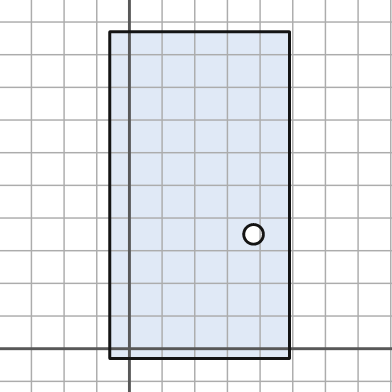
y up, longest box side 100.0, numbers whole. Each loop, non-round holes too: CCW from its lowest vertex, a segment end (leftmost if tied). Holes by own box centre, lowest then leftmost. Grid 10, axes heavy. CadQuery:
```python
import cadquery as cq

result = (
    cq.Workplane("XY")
    .moveTo(-6.0, -3.0)
    .lineTo(49.0, -3.0)
    .lineTo(49.0, 97.0)
    .lineTo(-6.0, 97.0)
    .close()
    .moveTo(38.0, 35.0)
    .circle(3.0)
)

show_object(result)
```